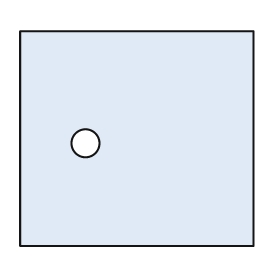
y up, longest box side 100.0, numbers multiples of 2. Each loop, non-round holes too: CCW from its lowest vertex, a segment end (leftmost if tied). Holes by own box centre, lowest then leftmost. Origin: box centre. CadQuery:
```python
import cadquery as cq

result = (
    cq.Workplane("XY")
    .moveTo(-50.0, -46.0)
    .lineTo(50.0, -46.0)
    .lineTo(50.0, 46.0)
    .lineTo(-50.0, 46.0)
    .close()
    .moveTo(-22.0, -2.0)
    .circle(6.0)
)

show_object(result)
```